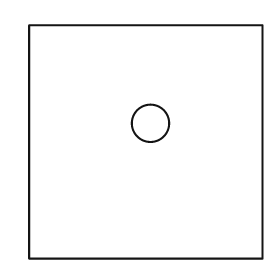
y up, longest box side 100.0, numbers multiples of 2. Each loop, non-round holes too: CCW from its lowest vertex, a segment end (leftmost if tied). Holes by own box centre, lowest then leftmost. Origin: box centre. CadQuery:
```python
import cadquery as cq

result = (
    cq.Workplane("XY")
    .moveTo(-50.0, -50.0)
    .lineTo(50.0, -50.0)
    .lineTo(50.0, 50.0)
    .lineTo(-50.0, 50.0)
    .close()
    .moveTo(2.0, 8.0)
    .circle(8.0)
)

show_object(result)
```